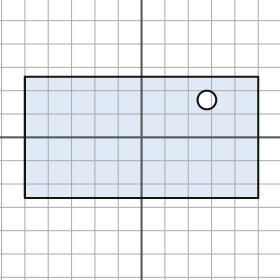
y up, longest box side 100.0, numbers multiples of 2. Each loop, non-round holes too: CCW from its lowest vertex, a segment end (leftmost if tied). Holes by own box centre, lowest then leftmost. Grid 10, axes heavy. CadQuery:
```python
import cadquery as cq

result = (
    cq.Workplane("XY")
    .moveTo(-50.0, -26.0)
    .lineTo(50.0, -26.0)
    .lineTo(50.0, 26.0)
    .lineTo(-50.0, 26.0)
    .close()
    .moveTo(28.0, 16.0)
    .circle(4.0)
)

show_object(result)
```